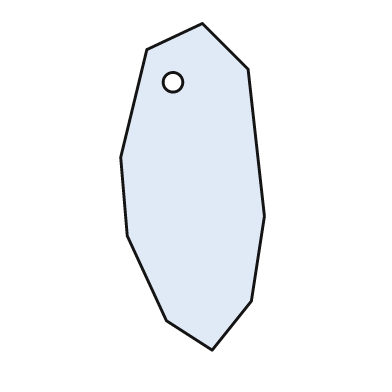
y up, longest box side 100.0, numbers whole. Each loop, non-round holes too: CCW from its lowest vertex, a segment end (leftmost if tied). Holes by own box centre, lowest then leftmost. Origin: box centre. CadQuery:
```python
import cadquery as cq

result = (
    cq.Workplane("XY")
    .moveTo(6.0, -50.0)
    .lineTo(18.0, -35.0)
    .lineTo(22.0, -9.0)
    .lineTo(17.0, 36.0)
    .lineTo(3.0, 50.0)
    .lineTo(-14.0, 42.0)
    .lineTo(-22.0, 9.0)
    .lineTo(-20.0, -15.0)
    .lineTo(-8.0, -41.0)
    .close()
    .moveTo(-6.0, 32.0)
    .circle(3.0)
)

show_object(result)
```